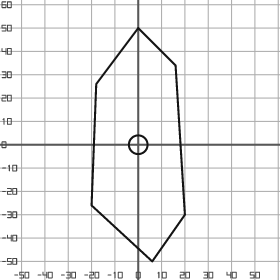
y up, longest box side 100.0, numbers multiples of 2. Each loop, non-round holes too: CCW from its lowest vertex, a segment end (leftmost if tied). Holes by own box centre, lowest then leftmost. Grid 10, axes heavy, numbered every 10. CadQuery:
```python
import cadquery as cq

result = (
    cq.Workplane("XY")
    .moveTo(6.0, -50.0)
    .lineTo(20.0, -30.0)
    .lineTo(16.0, 34.0)
    .lineTo(0.0, 50.0)
    .lineTo(-18.0, 26.0)
    .lineTo(-20.0, -26.0)
    .close()
    .moveTo(0.0, 0.0)
    .circle(4.0)
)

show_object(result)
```